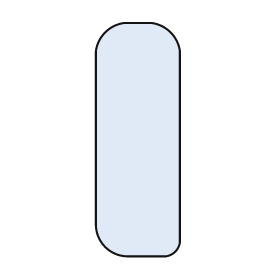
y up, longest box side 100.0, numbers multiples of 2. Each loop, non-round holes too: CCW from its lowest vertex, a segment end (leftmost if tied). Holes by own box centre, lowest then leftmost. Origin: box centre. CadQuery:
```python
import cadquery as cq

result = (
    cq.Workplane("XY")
    .moveTo(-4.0, -50.0)
    .lineTo(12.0, -50.0)
    .threePointArc((16.0, -48.0), (18.0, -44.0))
    .lineTo(18.0, 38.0)
    .threePointArc((14.0, 46.0), (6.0, 50.0))
    .lineTo(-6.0, 50.0)
    .threePointArc((-14.0, 46.0), (-18.0, 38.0))
    .lineTo(-18.0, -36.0)
    .threePointArc((-14.0, -46.0), (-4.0, -50.0))
    .close()
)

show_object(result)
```